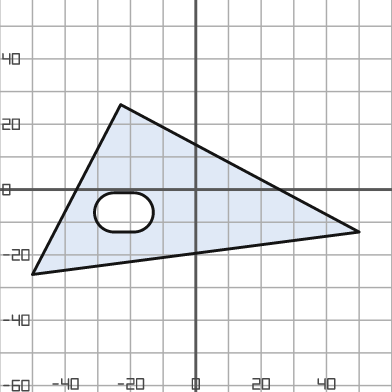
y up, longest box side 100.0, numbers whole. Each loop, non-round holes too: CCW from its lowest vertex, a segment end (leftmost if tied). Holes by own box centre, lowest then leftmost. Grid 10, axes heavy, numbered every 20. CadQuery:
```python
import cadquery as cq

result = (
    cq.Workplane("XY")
    .moveTo(-50.0, -26.0)
    .lineTo(50.0, -13.0)
    .lineTo(-23.0, 26.0)
    .close()
    .moveTo(-25.0, -13.0)
    .lineTo(-19.0, -13.0)
    .threePointArc((-13.0, -7.0), (-19.0, -1.0))
    .lineTo(-25.0, -1.0)
    .threePointArc((-31.0, -7.0), (-25.0, -13.0))
    .close()
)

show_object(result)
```